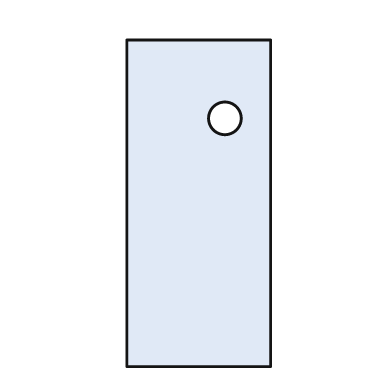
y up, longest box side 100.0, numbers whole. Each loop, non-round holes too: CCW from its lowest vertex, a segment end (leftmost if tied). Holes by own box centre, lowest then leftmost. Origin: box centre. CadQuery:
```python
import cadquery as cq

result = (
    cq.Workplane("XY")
    .moveTo(-22.0, -50.0)
    .lineTo(22.0, -50.0)
    .lineTo(22.0, 50.0)
    .lineTo(-22.0, 50.0)
    .close()
    .moveTo(8.0, 26.0)
    .circle(5.0)
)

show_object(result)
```